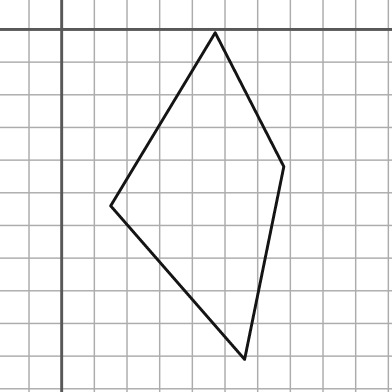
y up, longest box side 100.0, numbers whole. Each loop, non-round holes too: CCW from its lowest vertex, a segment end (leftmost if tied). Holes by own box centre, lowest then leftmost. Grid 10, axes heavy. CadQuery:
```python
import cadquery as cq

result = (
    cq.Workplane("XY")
    .moveTo(56.0, -101.0)
    .lineTo(68.0, -42.0)
    .lineTo(47.0, -1.0)
    .lineTo(15.0, -54.0)
    .close()
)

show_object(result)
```